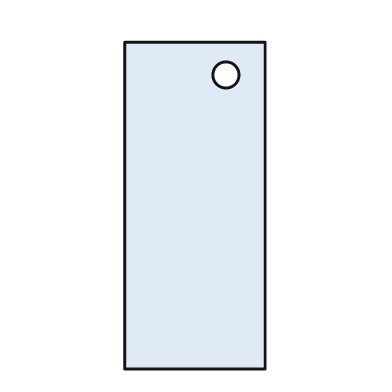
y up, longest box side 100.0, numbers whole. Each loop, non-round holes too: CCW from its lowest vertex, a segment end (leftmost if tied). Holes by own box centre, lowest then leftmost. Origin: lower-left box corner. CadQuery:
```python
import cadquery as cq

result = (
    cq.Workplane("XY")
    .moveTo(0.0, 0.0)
    .lineTo(43.0, 0.0)
    .lineTo(43.0, 100.0)
    .lineTo(0.0, 100.0)
    .close()
    .moveTo(31.0, 90.0)
    .circle(4.0)
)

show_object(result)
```